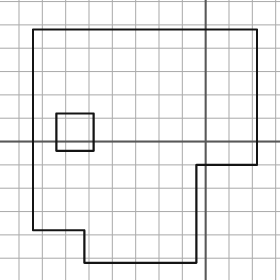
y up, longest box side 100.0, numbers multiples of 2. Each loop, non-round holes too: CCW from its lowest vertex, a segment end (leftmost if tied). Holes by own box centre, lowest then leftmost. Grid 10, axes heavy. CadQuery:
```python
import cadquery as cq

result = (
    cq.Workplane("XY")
    .moveTo(-52.0, -52.0)
    .lineTo(-4.0, -52.0)
    .lineTo(-4.0, -10.0)
    .lineTo(22.0, -10.0)
    .lineTo(22.0, 48.0)
    .lineTo(-74.0, 48.0)
    .lineTo(-74.0, -38.0)
    .lineTo(-52.0, -38.0)
    .close()
    .moveTo(-64.0, -4.0)
    .lineTo(-48.0, -4.0)
    .lineTo(-48.0, 12.0)
    .lineTo(-64.0, 12.0)
    .close()
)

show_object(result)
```